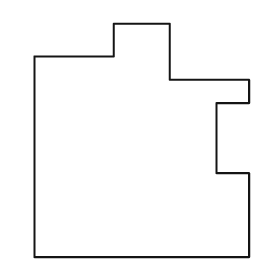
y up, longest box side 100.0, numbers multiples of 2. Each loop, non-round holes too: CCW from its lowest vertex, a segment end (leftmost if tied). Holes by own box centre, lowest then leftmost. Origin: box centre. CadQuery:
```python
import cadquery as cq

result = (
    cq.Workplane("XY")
    .moveTo(-46.0, -50.0)
    .lineTo(46.0, -50.0)
    .lineTo(46.0, -14.0)
    .lineTo(32.0, -14.0)
    .lineTo(32.0, 16.0)
    .lineTo(46.0, 16.0)
    .lineTo(46.0, 26.0)
    .lineTo(12.0, 26.0)
    .lineTo(12.0, 50.0)
    .lineTo(-12.0, 50.0)
    .lineTo(-12.0, 36.0)
    .lineTo(-46.0, 36.0)
    .close()
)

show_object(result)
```